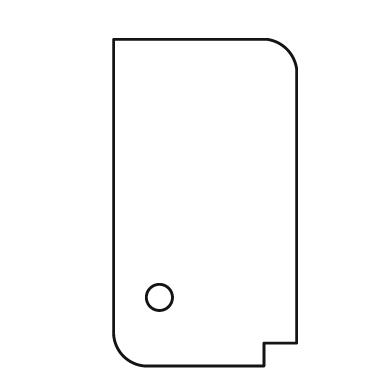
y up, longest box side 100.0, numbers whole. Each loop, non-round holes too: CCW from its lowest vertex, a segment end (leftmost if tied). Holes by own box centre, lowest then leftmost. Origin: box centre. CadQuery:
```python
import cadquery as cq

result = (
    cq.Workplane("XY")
    .moveTo(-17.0, -50.0)
    .lineTo(18.0, -50.0)
    .lineTo(18.0, -43.0)
    .lineTo(28.0, -43.0)
    .lineTo(28.0, 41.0)
    .threePointArc((25.0, 47.0), (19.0, 50.0))
    .lineTo(-28.0, 50.0)
    .lineTo(-28.0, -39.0)
    .threePointArc((-25.0, -47.0), (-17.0, -50.0))
    .close()
    .moveTo(-14.0, -29.0)
    .circle(4.0)
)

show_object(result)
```